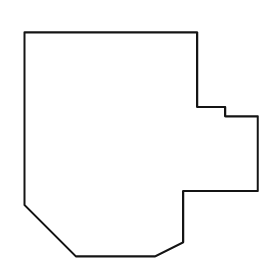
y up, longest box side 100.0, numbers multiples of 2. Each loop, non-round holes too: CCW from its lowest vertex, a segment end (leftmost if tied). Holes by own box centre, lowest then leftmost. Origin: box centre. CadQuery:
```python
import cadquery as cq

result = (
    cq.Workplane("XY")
    .moveTo(-28.0, -48.0)
    .lineTo(6.0, -48.0)
    .lineTo(18.0, -42.0)
    .lineTo(18.0, -20.0)
    .lineTo(50.0, -20.0)
    .lineTo(50.0, 12.0)
    .lineTo(36.0, 12.0)
    .lineTo(36.0, 16.0)
    .lineTo(24.0, 16.0)
    .lineTo(24.0, 48.0)
    .lineTo(-50.0, 48.0)
    .lineTo(-50.0, -26.0)
    .close()
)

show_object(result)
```